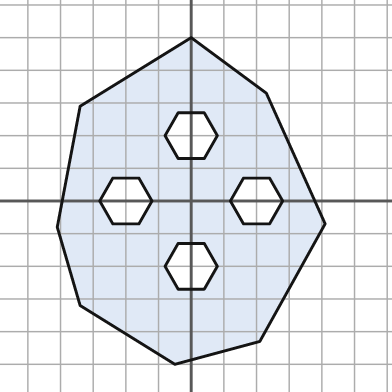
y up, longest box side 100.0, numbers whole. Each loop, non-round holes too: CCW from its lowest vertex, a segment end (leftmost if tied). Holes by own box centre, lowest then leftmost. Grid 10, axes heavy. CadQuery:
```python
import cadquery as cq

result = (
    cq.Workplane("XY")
    .moveTo(-5.0, -50.0)
    .lineTo(21.0, -43.0)
    .lineTo(41.0, -7.0)
    .lineTo(23.0, 33.0)
    .lineTo(0.0, 50.0)
    .lineTo(-34.0, 29.0)
    .lineTo(-41.0, -8.0)
    .lineTo(-34.0, -32.0)
    .close()
    .moveTo(-4.0, -27.0)
    .lineTo(4.0, -27.0)
    .lineTo(8.0, -20.0)
    .lineTo(4.0, -13.0)
    .lineTo(-4.0, -13.0)
    .lineTo(-8.0, -20.0)
    .close()
    .moveTo(-24.0, -7.0)
    .lineTo(-16.0, -7.0)
    .lineTo(-12.0, 0.0)
    .lineTo(-16.0, 7.0)
    .lineTo(-24.0, 7.0)
    .lineTo(-28.0, 0.0)
    .close()
    .moveTo(16.0, -7.0)
    .lineTo(24.0, -7.0)
    .lineTo(28.0, 0.0)
    .lineTo(24.0, 7.0)
    .lineTo(16.0, 7.0)
    .lineTo(12.0, 0.0)
    .close()
    .moveTo(-4.0, 13.0)
    .lineTo(4.0, 13.0)
    .lineTo(8.0, 20.0)
    .lineTo(4.0, 27.0)
    .lineTo(-4.0, 27.0)
    .lineTo(-8.0, 20.0)
    .close()
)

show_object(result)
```